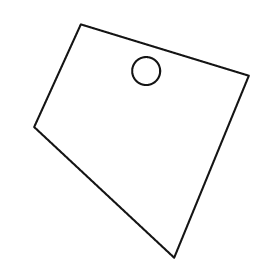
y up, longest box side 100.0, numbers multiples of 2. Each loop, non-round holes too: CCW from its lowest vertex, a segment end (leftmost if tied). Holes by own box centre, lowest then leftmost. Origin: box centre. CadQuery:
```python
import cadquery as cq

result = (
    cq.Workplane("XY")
    .moveTo(14.0, -50.0)
    .lineTo(46.0, 28.0)
    .lineTo(-26.0, 50.0)
    .lineTo(-46.0, 6.0)
    .close()
    .moveTo(2.0, 30.0)
    .circle(6.0)
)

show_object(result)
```